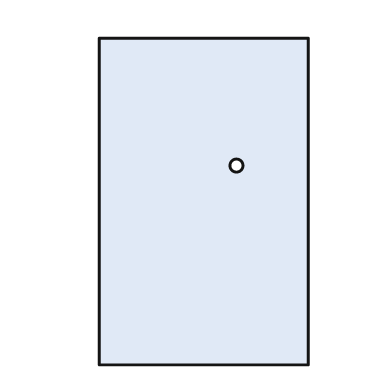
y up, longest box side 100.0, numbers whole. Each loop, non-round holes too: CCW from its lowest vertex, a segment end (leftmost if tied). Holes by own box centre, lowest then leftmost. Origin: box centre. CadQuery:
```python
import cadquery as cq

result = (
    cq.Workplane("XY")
    .moveTo(-32.0, -50.0)
    .lineTo(32.0, -50.0)
    .lineTo(32.0, 50.0)
    .lineTo(-32.0, 50.0)
    .close()
    .moveTo(10.0, 11.0)
    .circle(2.0)
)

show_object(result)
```